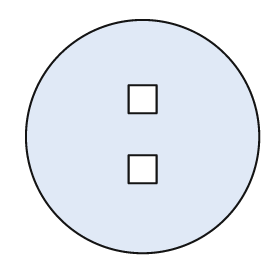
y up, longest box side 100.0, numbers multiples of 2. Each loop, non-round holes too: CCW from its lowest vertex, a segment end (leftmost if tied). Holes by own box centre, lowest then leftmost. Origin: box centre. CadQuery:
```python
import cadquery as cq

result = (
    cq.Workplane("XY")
    .moveTo(0.0, 0.0)
    .circle(50.0)
    .moveTo(-6.0, -20.0)
    .lineTo(6.0, -20.0)
    .lineTo(6.0, -8.0)
    .lineTo(-6.0, -8.0)
    .close()
    .moveTo(-6.0, 10.0)
    .lineTo(6.0, 10.0)
    .lineTo(6.0, 22.0)
    .lineTo(-6.0, 22.0)
    .close()
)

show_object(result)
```